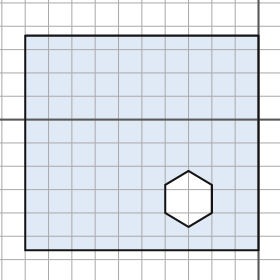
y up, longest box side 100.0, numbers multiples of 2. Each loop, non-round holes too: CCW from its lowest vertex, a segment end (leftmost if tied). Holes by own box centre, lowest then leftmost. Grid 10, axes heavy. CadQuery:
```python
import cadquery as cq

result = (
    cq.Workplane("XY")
    .moveTo(-100.0, -56.0)
    .lineTo(0.0, -56.0)
    .lineTo(0.0, 36.0)
    .lineTo(-100.0, 36.0)
    .close()
    .moveTo(-30.0, -46.0)
    .lineTo(-20.0, -40.0)
    .lineTo(-20.0, -28.0)
    .lineTo(-30.0, -22.0)
    .lineTo(-40.0, -28.0)
    .lineTo(-40.0, -40.0)
    .close()
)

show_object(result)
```